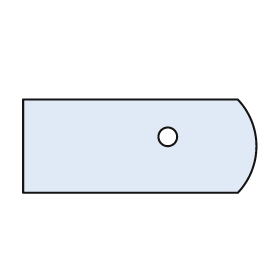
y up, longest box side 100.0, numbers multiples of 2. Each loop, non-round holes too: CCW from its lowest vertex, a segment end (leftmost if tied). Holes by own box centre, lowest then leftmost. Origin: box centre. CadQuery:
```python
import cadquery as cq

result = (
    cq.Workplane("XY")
    .moveTo(-50.0, -20.0)
    .lineTo(42.0, -20.0)
    .threePointArc((50.0, 0.0), (42.0, 20.0))
    .lineTo(-50.0, 20.0)
    .close()
    .moveTo(12.0, 4.0)
    .circle(4.0)
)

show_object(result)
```